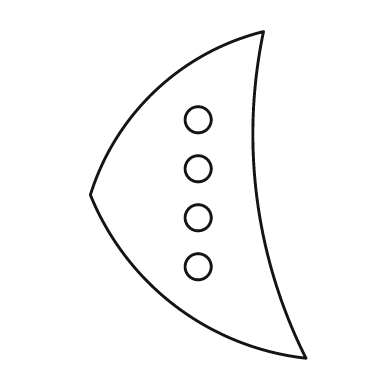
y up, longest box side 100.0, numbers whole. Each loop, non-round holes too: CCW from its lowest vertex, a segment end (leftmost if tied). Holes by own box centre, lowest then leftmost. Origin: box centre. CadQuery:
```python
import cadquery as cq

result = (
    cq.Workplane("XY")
    .moveTo(33.0, -50.0)
    .threePointArc((18.0, -1.0), (20.0, 50.0))
    .threePointArc((-13.0, 32.0), (-33.0, 0.0))
    .threePointArc((-7.0, -34.0), (33.0, -50.0))
    .close()
    .moveTo(0.0, -22.0)
    .circle(4.0)
    .moveTo(0.0, -7.0)
    .circle(4.0)
    .moveTo(0.0, 8.0)
    .circle(4.0)
    .moveTo(0.0, 23.0)
    .circle(4.0)
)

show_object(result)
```